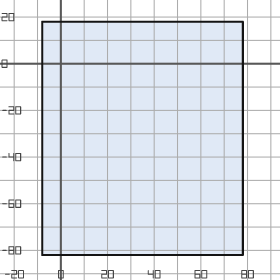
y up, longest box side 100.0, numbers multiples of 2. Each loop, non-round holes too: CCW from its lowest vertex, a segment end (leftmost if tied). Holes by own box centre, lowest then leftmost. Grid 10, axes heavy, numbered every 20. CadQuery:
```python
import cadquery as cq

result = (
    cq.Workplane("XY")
    .moveTo(-8.0, -82.0)
    .lineTo(78.0, -82.0)
    .lineTo(78.0, 18.0)
    .lineTo(-8.0, 18.0)
    .close()
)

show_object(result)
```